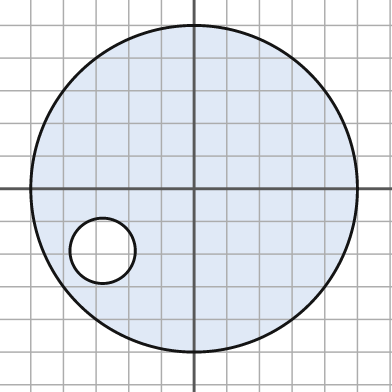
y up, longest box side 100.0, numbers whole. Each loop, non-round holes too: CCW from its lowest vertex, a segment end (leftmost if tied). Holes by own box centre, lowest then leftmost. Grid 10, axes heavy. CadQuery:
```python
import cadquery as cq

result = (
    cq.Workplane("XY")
    .moveTo(0.0, 0.0)
    .circle(50.0)
    .moveTo(-28.0, -19.0)
    .circle(10.0)
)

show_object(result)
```